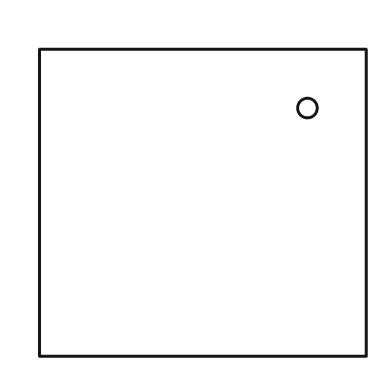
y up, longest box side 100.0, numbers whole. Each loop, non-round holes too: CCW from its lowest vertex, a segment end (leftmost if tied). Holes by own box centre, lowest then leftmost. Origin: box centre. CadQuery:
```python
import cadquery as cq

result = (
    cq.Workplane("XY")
    .moveTo(-50.0, -47.0)
    .lineTo(50.0, -47.0)
    .lineTo(50.0, 47.0)
    .lineTo(-50.0, 47.0)
    .close()
    .moveTo(32.0, 29.0)
    .circle(3.0)
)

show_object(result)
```